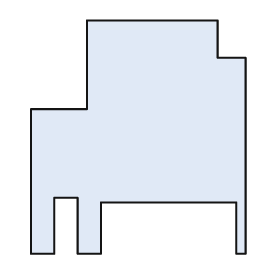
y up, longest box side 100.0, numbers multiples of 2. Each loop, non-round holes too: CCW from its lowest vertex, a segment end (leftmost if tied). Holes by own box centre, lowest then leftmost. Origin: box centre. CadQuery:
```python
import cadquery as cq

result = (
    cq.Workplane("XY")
    .moveTo(-46.0, -50.0)
    .lineTo(-36.0, -50.0)
    .lineTo(-36.0, -26.0)
    .lineTo(-26.0, -26.0)
    .lineTo(-26.0, -50.0)
    .lineTo(-16.0, -50.0)
    .lineTo(-16.0, -28.0)
    .lineTo(42.0, -28.0)
    .lineTo(42.0, -50.0)
    .lineTo(46.0, -50.0)
    .lineTo(46.0, 34.0)
    .lineTo(34.0, 34.0)
    .lineTo(34.0, 50.0)
    .lineTo(-22.0, 50.0)
    .lineTo(-22.0, 12.0)
    .lineTo(-46.0, 12.0)
    .close()
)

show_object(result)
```